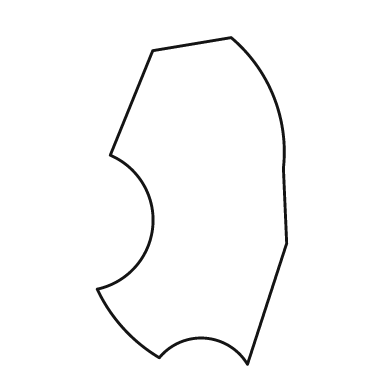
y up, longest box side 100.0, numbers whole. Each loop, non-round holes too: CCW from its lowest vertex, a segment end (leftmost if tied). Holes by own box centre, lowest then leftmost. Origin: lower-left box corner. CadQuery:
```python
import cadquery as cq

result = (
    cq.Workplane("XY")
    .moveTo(46.0, 0.0)
    .lineTo(58.0, 37.0)
    .lineTo(57.0, 60.0)
    .threePointArc((54.0, 82.0), (41.0, 100.0))
    .lineTo(17.0, 96.0)
    .lineTo(4.0, 64.0)
    .threePointArc((17.0, 42.0), (0.0, 23.0))
    .threePointArc((8.0, 11.0), (19.0, 2.0))
    .threePointArc((33.0, 8.0), (46.0, 0.0))
    .close()
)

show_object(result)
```